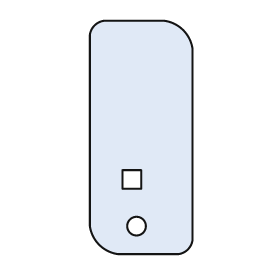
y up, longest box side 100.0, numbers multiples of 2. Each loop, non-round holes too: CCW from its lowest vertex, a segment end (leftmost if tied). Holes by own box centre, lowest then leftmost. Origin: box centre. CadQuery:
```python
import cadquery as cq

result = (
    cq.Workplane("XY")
    .moveTo(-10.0, -50.0)
    .lineTo(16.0, -50.0)
    .threePointArc((20.0, -48.0), (22.0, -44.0))
    .lineTo(22.0, 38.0)
    .threePointArc((18.0, 46.0), (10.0, 50.0))
    .lineTo(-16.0, 50.0)
    .threePointArc((-20.0, 48.0), (-22.0, 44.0))
    .lineTo(-22.0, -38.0)
    .threePointArc((-18.0, -46.0), (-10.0, -50.0))
    .close()
    .moveTo(-2.0, -38.0)
    .circle(4.0)
    .moveTo(-8.0, -22.0)
    .lineTo(0.0, -22.0)
    .lineTo(0.0, -14.0)
    .lineTo(-8.0, -14.0)
    .close()
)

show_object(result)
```